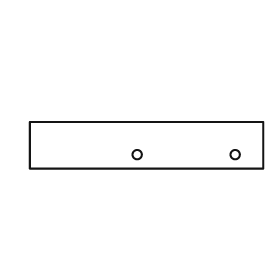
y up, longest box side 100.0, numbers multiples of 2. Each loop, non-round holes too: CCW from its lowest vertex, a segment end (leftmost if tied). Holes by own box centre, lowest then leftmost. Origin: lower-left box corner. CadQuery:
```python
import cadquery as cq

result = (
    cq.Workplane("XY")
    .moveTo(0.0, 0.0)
    .lineTo(100.0, 0.0)
    .lineTo(100.0, 20.0)
    .lineTo(0.0, 20.0)
    .close()
    .moveTo(46.0, 6.0)
    .circle(2.0)
    .moveTo(88.0, 6.0)
    .circle(2.0)
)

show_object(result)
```